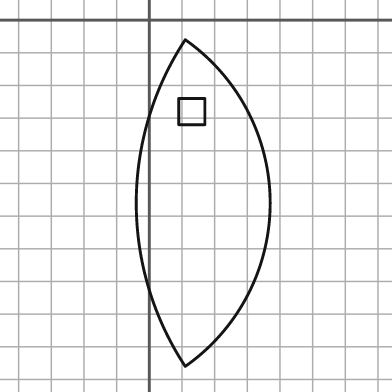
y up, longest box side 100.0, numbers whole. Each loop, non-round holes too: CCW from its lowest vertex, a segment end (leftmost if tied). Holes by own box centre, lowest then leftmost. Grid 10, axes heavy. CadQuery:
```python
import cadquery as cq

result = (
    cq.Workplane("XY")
    .moveTo(11.0, -106.0)
    .threePointArc((37.0, -56.0), (11.0, -6.0))
    .threePointArc((-4.0, -56.0), (11.0, -106.0))
    .close()
    .moveTo(9.0, -32.0)
    .lineTo(17.0, -32.0)
    .lineTo(17.0, -24.0)
    .lineTo(9.0, -24.0)
    .close()
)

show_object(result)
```